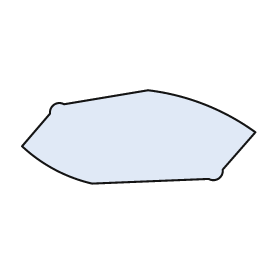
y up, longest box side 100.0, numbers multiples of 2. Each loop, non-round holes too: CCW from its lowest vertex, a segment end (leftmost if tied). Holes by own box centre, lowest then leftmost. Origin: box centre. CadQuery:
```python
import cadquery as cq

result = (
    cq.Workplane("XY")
    .moveTo(-20.0, -20.0)
    .lineTo(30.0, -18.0)
    .threePointArc((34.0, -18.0), (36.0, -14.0))
    .lineTo(50.0, 2.0)
    .threePointArc((28.0, 14.0), (4.0, 20.0))
    .lineTo(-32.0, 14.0)
    .threePointArc((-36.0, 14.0), (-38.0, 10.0))
    .lineTo(-50.0, -4.0)
    .threePointArc((-36.0, -14.0), (-20.0, -20.0))
    .close()
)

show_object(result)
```